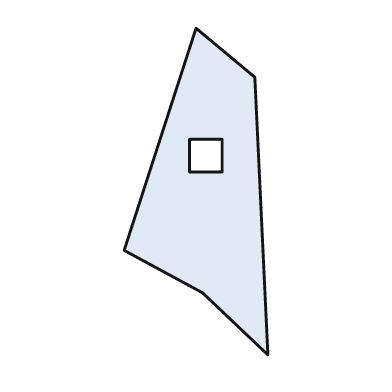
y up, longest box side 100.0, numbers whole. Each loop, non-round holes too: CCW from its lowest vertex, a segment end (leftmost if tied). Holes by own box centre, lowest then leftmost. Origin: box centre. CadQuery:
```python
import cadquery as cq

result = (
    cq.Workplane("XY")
    .moveTo(22.0, -50.0)
    .lineTo(18.0, 35.0)
    .lineTo(0.0, 50.0)
    .lineTo(-22.0, -18.0)
    .lineTo(2.0, -31.0)
    .close()
    .moveTo(-2.0, 6.0)
    .lineTo(8.0, 6.0)
    .lineTo(8.0, 16.0)
    .lineTo(-2.0, 16.0)
    .close()
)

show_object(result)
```